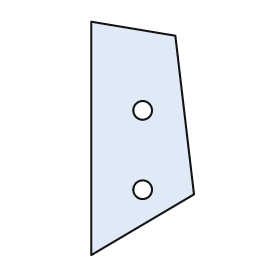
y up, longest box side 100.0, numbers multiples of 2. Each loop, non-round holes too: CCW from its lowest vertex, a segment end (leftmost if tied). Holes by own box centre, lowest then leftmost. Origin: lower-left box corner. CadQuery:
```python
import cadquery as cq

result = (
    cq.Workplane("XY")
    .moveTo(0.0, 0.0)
    .lineTo(44.0, 26.0)
    .lineTo(36.0, 94.0)
    .lineTo(0.0, 100.0)
    .close()
    .moveTo(22.0, 28.0)
    .circle(4.0)
    .moveTo(22.0, 62.0)
    .circle(4.0)
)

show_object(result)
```